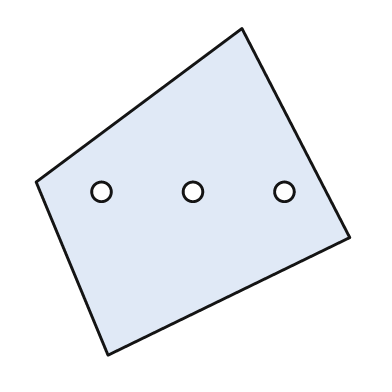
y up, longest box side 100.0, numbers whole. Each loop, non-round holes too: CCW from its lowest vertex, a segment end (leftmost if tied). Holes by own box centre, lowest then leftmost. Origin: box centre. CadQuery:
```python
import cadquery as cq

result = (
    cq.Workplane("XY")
    .moveTo(-26.0, -50.0)
    .lineTo(48.0, -14.0)
    .lineTo(15.0, 50.0)
    .lineTo(-48.0, 3.0)
    .close()
    .moveTo(-28.0, 0.0)
    .circle(3.0)
    .moveTo(0.0, 0.0)
    .circle(3.0)
    .moveTo(28.0, 0.0)
    .circle(3.0)
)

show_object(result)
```